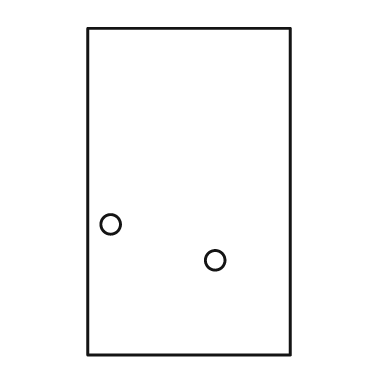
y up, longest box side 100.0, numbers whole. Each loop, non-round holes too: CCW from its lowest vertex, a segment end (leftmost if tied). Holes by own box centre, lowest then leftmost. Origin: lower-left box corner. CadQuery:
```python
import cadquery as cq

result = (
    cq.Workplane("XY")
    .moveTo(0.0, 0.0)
    .lineTo(62.0, 0.0)
    .lineTo(62.0, 100.0)
    .lineTo(0.0, 100.0)
    .close()
    .moveTo(39.0, 29.0)
    .circle(3.0)
    .moveTo(7.0, 40.0)
    .circle(3.0)
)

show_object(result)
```